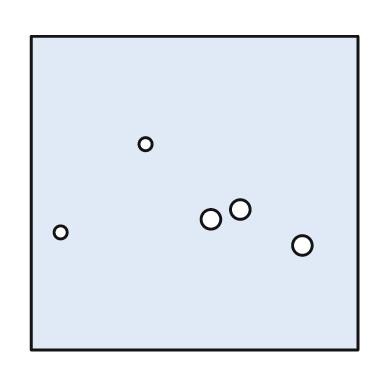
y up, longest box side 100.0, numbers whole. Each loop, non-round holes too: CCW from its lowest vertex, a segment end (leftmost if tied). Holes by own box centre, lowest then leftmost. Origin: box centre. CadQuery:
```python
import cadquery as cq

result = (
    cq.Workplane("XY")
    .moveTo(-50.0, -48.0)
    .lineTo(50.0, -48.0)
    .lineTo(50.0, 48.0)
    .lineTo(-50.0, 48.0)
    .close()
    .moveTo(33.0, -16.0)
    .circle(3.0)
    .moveTo(-41.0, -12.0)
    .circle(2.0)
    .moveTo(5.0, -8.0)
    .circle(3.0)
    .moveTo(14.0, -5.0)
    .circle(3.0)
    .moveTo(-15.0, 15.0)
    .circle(2.0)
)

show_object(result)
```